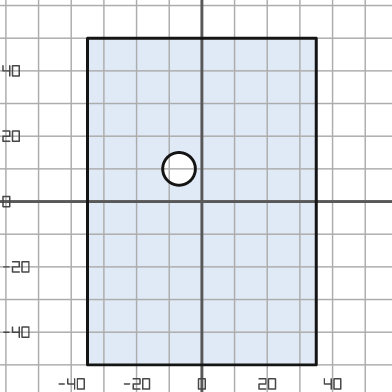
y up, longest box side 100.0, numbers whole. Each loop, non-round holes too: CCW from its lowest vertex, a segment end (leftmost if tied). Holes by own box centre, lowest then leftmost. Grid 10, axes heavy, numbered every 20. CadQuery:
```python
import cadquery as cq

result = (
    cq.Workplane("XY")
    .moveTo(-35.0, -50.0)
    .lineTo(35.0, -50.0)
    .lineTo(35.0, 50.0)
    .lineTo(-35.0, 50.0)
    .close()
    .moveTo(-7.0, 10.0)
    .circle(5.0)
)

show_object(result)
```